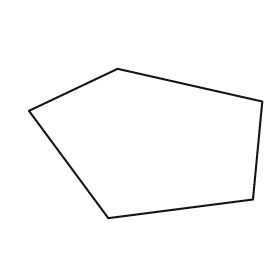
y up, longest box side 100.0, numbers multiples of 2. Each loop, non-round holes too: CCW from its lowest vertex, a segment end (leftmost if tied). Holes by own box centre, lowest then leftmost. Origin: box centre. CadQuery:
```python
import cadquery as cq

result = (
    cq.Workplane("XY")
    .moveTo(-16.0, -32.0)
    .lineTo(46.0, -24.0)
    .lineTo(50.0, 18.0)
    .lineTo(-12.0, 32.0)
    .lineTo(-50.0, 14.0)
    .close()
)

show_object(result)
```